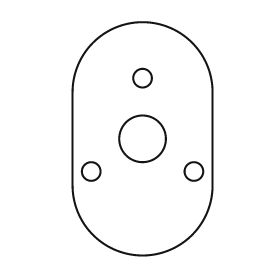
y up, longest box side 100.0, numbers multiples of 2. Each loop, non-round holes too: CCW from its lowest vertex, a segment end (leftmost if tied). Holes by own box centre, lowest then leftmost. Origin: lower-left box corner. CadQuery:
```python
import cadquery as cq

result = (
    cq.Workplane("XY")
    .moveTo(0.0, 30.0)
    .threePointArc((30.0, 0.0), (60.0, 30.0))
    .lineTo(60.0, 70.0)
    .threePointArc((30.0, 100.0), (0.0, 70.0))
    .close()
    .moveTo(8.0, 36.0)
    .circle(4.0)
    .moveTo(52.0, 36.0)
    .circle(4.0)
    .moveTo(30.0, 50.0)
    .circle(10.0)
    .moveTo(30.0, 76.0)
    .circle(4.0)
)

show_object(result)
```